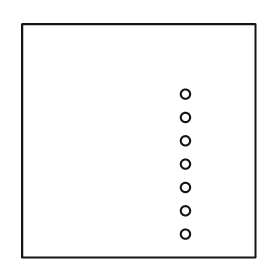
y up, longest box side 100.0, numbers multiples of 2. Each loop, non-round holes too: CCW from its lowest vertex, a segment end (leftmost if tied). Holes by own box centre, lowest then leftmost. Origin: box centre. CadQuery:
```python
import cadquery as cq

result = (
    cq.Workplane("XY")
    .moveTo(-50.0, -50.0)
    .lineTo(50.0, -50.0)
    .lineTo(50.0, 50.0)
    .lineTo(-50.0, 50.0)
    .close()
    .moveTo(20.0, -40.0)
    .circle(2.0)
    .moveTo(20.0, -30.0)
    .circle(2.0)
    .moveTo(20.0, -20.0)
    .circle(2.0)
    .moveTo(20.0, -10.0)
    .circle(2.0)
    .moveTo(20.0, 0.0)
    .circle(2.0)
    .moveTo(20.0, 10.0)
    .circle(2.0)
    .moveTo(20.0, 20.0)
    .circle(2.0)
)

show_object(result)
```